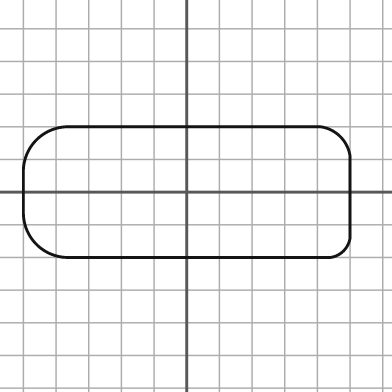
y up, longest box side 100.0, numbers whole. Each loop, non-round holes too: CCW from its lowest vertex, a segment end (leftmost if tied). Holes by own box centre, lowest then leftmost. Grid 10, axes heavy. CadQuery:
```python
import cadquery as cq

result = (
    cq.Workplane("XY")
    .moveTo(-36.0, -20.0)
    .lineTo(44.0, -20.0)
    .threePointArc((48.0, -18.0), (50.0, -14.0))
    .lineTo(50.0, 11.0)
    .threePointArc((47.0, 17.0), (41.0, 20.0))
    .lineTo(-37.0, 20.0)
    .threePointArc((-46.0, 16.0), (-50.0, 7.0))
    .lineTo(-50.0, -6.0)
    .threePointArc((-46.0, -16.0), (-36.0, -20.0))
    .close()
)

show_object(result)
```